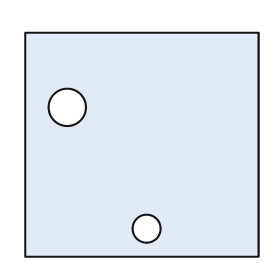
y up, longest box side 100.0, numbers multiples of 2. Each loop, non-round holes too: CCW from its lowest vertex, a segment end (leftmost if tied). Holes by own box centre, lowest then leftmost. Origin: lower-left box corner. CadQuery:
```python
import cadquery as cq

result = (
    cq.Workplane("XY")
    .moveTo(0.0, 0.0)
    .lineTo(100.0, 0.0)
    .lineTo(100.0, 96.0)
    .lineTo(0.0, 96.0)
    .close()
    .moveTo(52.0, 12.0)
    .circle(6.0)
    .moveTo(18.0, 64.0)
    .circle(8.0)
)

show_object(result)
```